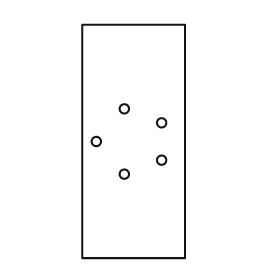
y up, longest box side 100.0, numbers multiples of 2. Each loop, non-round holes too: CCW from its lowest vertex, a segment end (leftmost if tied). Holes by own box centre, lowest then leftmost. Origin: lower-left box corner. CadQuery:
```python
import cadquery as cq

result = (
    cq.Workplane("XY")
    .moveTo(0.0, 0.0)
    .lineTo(44.0, 0.0)
    .lineTo(44.0, 100.0)
    .lineTo(0.0, 100.0)
    .close()
    .moveTo(18.0, 36.0)
    .circle(2.0)
    .moveTo(34.0, 42.0)
    .circle(2.0)
    .moveTo(6.0, 50.0)
    .circle(2.0)
    .moveTo(34.0, 58.0)
    .circle(2.0)
    .moveTo(18.0, 64.0)
    .circle(2.0)
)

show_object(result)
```